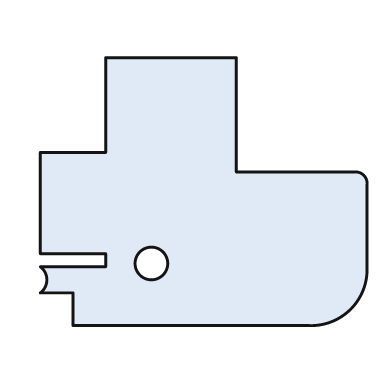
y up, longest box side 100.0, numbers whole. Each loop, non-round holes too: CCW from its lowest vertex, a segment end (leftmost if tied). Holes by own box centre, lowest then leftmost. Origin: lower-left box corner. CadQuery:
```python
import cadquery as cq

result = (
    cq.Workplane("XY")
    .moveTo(10.0, 0.0)
    .lineTo(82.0, 0.0)
    .threePointArc((95.0, 5.0), (100.0, 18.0))
    .lineTo(100.0, 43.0)
    .threePointArc((99.0, 46.0), (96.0, 47.0))
    .lineTo(60.0, 47.0)
    .lineTo(60.0, 82.0)
    .lineTo(20.0, 82.0)
    .lineTo(20.0, 53.0)
    .lineTo(0.0, 53.0)
    .lineTo(0.0, 22.0)
    .lineTo(20.0, 22.0)
    .lineTo(20.0, 18.0)
    .lineTo(0.0, 18.0)
    .threePointArc((2.0, 14.0), (0.0, 10.0))
    .lineTo(10.0, 10.0)
    .close()
    .moveTo(34.0, 19.0)
    .circle(5.0)
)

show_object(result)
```